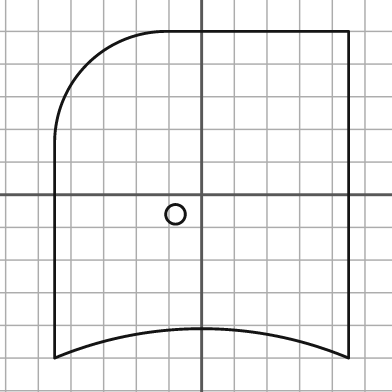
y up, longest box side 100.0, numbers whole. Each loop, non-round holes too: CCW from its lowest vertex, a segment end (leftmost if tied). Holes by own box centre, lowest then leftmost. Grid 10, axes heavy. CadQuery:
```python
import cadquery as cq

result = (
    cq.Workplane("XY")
    .moveTo(-45.0, -50.0)
    .threePointArc((0.0, -41.0), (45.0, -50.0))
    .lineTo(45.0, 50.0)
    .lineTo(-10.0, 50.0)
    .threePointArc((-35.0, 40.0), (-45.0, 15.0))
    .close()
    .moveTo(-8.0, -6.0)
    .circle(3.0)
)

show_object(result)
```